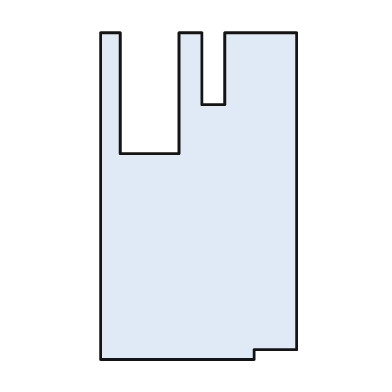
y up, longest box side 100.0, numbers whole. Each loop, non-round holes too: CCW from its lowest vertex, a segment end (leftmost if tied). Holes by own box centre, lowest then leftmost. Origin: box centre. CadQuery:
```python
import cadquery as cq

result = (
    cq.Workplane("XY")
    .moveTo(-30.0, -50.0)
    .lineTo(17.0, -50.0)
    .lineTo(17.0, -47.0)
    .lineTo(30.0, -47.0)
    .lineTo(30.0, 50.0)
    .lineTo(8.0, 50.0)
    .lineTo(8.0, 28.0)
    .lineTo(1.0, 28.0)
    .lineTo(1.0, 50.0)
    .lineTo(-6.0, 50.0)
    .lineTo(-6.0, 13.0)
    .lineTo(-24.0, 13.0)
    .lineTo(-24.0, 50.0)
    .lineTo(-30.0, 50.0)
    .close()
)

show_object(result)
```